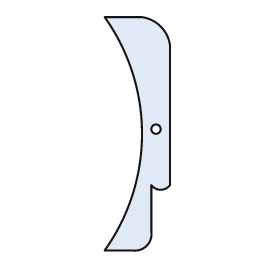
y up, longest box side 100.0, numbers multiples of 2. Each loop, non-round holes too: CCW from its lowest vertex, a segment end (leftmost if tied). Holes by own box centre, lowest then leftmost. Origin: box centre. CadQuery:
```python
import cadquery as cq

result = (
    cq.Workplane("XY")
    .moveTo(-14.0, -50.0)
    .lineTo(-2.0, -50.0)
    .threePointArc((4.0, -48.0), (6.0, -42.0))
    .lineTo(6.0, -22.0)
    .threePointArc((10.0, -24.0), (14.0, -22.0))
    .lineTo(14.0, 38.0)
    .threePointArc((10.0, 46.0), (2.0, 50.0))
    .lineTo(-14.0, 50.0)
    .threePointArc((2.0, 0.0), (-14.0, -50.0))
    .close()
    .moveTo(8.0, 2.0)
    .circle(2.0)
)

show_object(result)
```